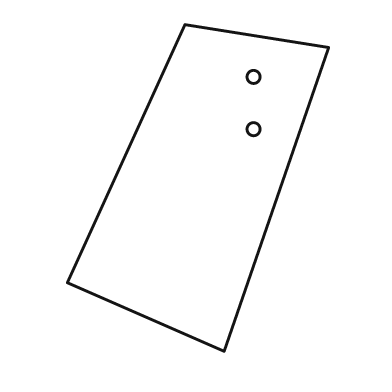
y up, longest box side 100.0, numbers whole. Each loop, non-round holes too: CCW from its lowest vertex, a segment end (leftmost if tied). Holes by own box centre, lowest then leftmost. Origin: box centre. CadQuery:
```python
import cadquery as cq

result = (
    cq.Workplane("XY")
    .moveTo(8.0, -50.0)
    .lineTo(40.0, 43.0)
    .lineTo(-4.0, 50.0)
    .lineTo(-40.0, -29.0)
    .close()
    .moveTo(17.0, 18.0)
    .circle(2.0)
    .moveTo(17.0, 34.0)
    .circle(2.0)
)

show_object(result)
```